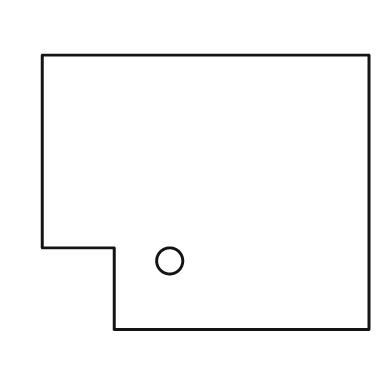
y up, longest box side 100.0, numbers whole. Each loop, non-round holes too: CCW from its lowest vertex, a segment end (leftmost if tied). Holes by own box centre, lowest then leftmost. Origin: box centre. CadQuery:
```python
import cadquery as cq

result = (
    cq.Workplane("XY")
    .moveTo(-28.0, -42.0)
    .lineTo(50.0, -42.0)
    .lineTo(50.0, 42.0)
    .lineTo(-50.0, 42.0)
    .lineTo(-50.0, -17.0)
    .lineTo(-28.0, -17.0)
    .close()
    .moveTo(-11.0, -21.0)
    .circle(4.0)
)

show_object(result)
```